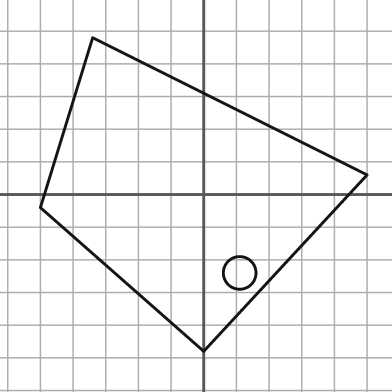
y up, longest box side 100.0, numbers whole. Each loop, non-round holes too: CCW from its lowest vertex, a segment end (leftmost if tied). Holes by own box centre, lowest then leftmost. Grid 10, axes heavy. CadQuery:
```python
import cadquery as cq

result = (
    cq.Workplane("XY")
    .moveTo(0.0, -48.0)
    .lineTo(50.0, 6.0)
    .lineTo(-34.0, 48.0)
    .lineTo(-50.0, -4.0)
    .close()
    .moveTo(11.0, -24.0)
    .circle(5.0)
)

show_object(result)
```